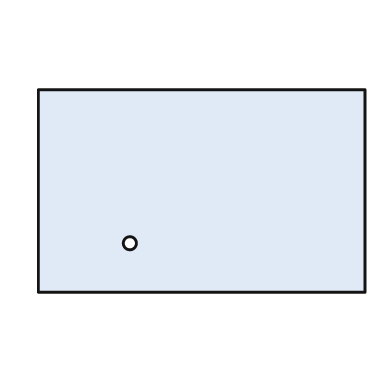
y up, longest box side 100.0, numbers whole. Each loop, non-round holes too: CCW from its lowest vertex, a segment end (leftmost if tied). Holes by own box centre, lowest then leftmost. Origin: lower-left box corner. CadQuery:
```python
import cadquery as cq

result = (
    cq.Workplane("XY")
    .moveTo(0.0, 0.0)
    .lineTo(100.0, 0.0)
    .lineTo(100.0, 62.0)
    .lineTo(0.0, 62.0)
    .close()
    .moveTo(28.0, 15.0)
    .circle(2.0)
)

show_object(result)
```